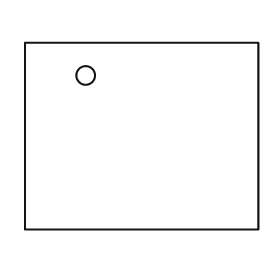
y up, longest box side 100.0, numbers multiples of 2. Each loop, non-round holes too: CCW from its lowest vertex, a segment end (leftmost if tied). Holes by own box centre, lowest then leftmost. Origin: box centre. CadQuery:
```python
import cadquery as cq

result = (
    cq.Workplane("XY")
    .moveTo(-50.0, -40.0)
    .lineTo(50.0, -40.0)
    .lineTo(50.0, 40.0)
    .lineTo(-50.0, 40.0)
    .close()
    .moveTo(-24.0, 26.0)
    .circle(4.0)
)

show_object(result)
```